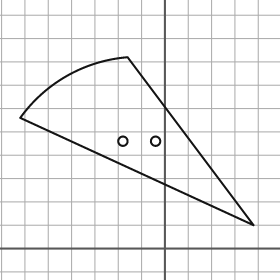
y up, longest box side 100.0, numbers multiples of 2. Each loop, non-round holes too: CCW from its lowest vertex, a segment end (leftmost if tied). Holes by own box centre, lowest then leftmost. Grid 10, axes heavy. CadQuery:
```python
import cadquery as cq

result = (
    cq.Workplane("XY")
    .moveTo(38.0, 10.0)
    .lineTo(-16.0, 82.0)
    .threePointArc((-42.0, 74.0), (-62.0, 56.0))
    .close()
    .moveTo(-18.0, 46.0)
    .circle(2.0)
    .moveTo(-4.0, 46.0)
    .circle(2.0)
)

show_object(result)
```